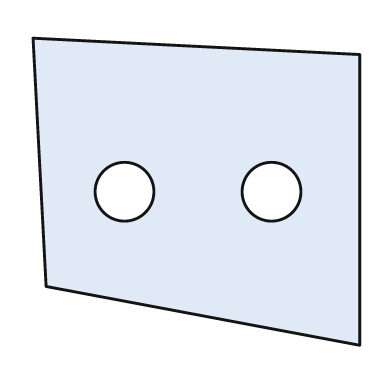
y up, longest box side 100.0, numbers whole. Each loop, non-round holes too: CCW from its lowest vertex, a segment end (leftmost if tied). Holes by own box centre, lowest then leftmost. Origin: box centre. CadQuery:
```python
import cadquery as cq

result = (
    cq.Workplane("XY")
    .moveTo(50.0, -47.0)
    .lineTo(50.0, 42.0)
    .lineTo(-50.0, 47.0)
    .lineTo(-46.0, -29.0)
    .close()
    .moveTo(-22.0, 0.0)
    .circle(9.0)
    .moveTo(23.0, 0.0)
    .circle(9.0)
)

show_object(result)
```